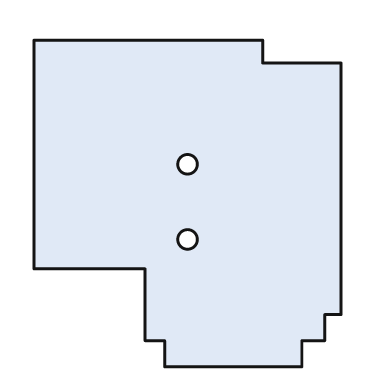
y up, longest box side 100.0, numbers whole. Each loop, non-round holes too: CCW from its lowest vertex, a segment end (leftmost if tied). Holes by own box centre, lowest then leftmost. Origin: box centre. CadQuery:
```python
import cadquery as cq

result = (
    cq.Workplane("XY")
    .moveTo(-7.0, -50.0)
    .lineTo(35.0, -50.0)
    .lineTo(35.0, -42.0)
    .lineTo(42.0, -42.0)
    .lineTo(42.0, -34.0)
    .lineTo(47.0, -34.0)
    .lineTo(47.0, 43.0)
    .lineTo(23.0, 43.0)
    .lineTo(23.0, 50.0)
    .lineTo(-47.0, 50.0)
    .lineTo(-47.0, -20.0)
    .lineTo(-13.0, -20.0)
    .lineTo(-13.0, -42.0)
    .lineTo(-7.0, -42.0)
    .close()
    .moveTo(0.0, -11.0)
    .circle(3.0)
    .moveTo(0.0, 12.0)
    .circle(3.0)
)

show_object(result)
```